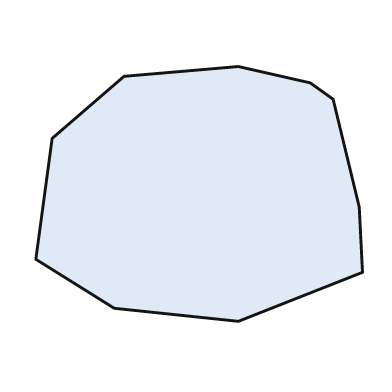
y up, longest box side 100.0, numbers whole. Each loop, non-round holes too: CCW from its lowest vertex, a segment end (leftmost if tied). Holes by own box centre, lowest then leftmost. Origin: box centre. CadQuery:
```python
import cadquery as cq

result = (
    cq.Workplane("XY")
    .moveTo(12.0, -39.0)
    .lineTo(50.0, -24.0)
    .lineTo(49.0, -4.0)
    .lineTo(41.0, 29.0)
    .lineTo(34.0, 34.0)
    .lineTo(12.0, 39.0)
    .lineTo(-23.0, 36.0)
    .lineTo(-45.0, 17.0)
    .lineTo(-50.0, -20.0)
    .lineTo(-26.0, -35.0)
    .close()
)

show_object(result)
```